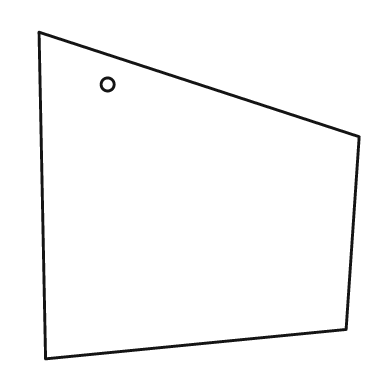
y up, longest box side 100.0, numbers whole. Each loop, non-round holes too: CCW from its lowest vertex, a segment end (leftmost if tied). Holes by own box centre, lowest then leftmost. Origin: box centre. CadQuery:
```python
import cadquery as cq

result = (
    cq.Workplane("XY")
    .moveTo(-47.0, -50.0)
    .lineTo(45.0, -41.0)
    .lineTo(49.0, 18.0)
    .lineTo(-49.0, 50.0)
    .close()
    .moveTo(-28.0, 34.0)
    .circle(2.0)
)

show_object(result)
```